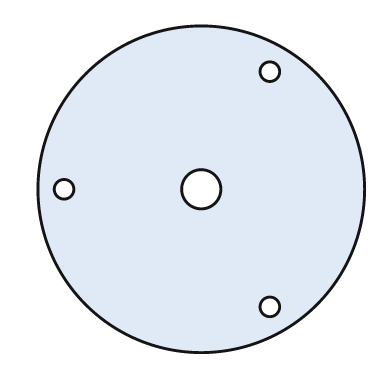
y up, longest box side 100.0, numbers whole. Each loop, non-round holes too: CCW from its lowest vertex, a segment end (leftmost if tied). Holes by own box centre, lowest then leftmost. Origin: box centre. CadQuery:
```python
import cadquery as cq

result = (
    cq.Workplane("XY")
    .moveTo(0.0, 0.0)
    .circle(50.0)
    .moveTo(21.0, -36.0)
    .circle(3.0)
    .moveTo(-42.0, 0.0)
    .circle(3.0)
    .moveTo(0.0, 0.0)
    .circle(6.0)
    .moveTo(21.0, 36.0)
    .circle(3.0)
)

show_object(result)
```